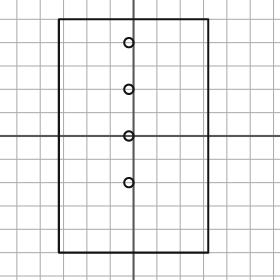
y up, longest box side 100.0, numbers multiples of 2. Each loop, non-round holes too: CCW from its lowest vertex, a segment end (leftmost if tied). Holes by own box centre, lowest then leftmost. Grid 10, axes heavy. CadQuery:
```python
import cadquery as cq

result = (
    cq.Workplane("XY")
    .moveTo(-32.0, -50.0)
    .lineTo(32.0, -50.0)
    .lineTo(32.0, 50.0)
    .lineTo(-32.0, 50.0)
    .close()
    .moveTo(-2.0, -20.0)
    .circle(2.0)
    .moveTo(-2.0, 0.0)
    .circle(2.0)
    .moveTo(-2.0, 20.0)
    .circle(2.0)
    .moveTo(-2.0, 40.0)
    .circle(2.0)
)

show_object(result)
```